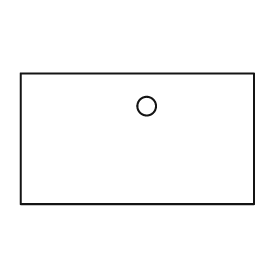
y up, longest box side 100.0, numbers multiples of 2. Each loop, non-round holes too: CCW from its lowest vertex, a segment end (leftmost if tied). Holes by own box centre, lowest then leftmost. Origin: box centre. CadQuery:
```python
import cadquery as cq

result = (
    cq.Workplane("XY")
    .moveTo(-50.0, -28.0)
    .lineTo(50.0, -28.0)
    .lineTo(50.0, 28.0)
    .lineTo(-50.0, 28.0)
    .close()
    .moveTo(4.0, 14.0)
    .circle(4.0)
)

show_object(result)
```